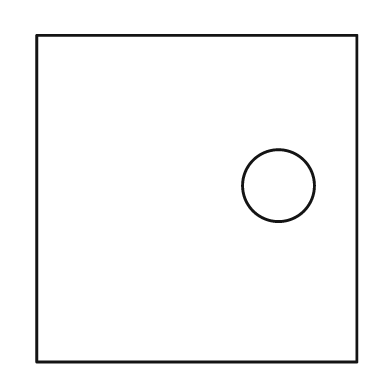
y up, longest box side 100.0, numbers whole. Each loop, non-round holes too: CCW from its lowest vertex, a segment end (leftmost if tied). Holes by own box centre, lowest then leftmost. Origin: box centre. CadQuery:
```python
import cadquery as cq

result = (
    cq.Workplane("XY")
    .moveTo(-49.0, -50.0)
    .lineTo(49.0, -50.0)
    .lineTo(49.0, 50.0)
    .lineTo(-49.0, 50.0)
    .close()
    .moveTo(25.0, 4.0)
    .circle(11.0)
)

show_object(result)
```